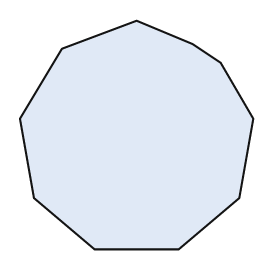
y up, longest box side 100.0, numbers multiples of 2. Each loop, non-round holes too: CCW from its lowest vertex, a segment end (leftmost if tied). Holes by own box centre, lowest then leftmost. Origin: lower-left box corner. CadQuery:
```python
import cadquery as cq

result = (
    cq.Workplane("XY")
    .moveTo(32.0, 0.0)
    .lineTo(68.0, 0.0)
    .lineTo(94.0, 22.0)
    .lineTo(100.0, 56.0)
    .lineTo(86.0, 80.0)
    .lineTo(74.0, 88.0)
    .lineTo(50.0, 98.0)
    .lineTo(18.0, 86.0)
    .lineTo(0.0, 56.0)
    .lineTo(6.0, 22.0)
    .close()
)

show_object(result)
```